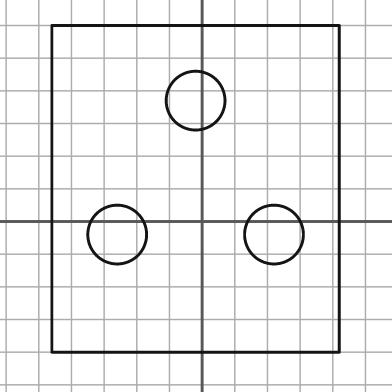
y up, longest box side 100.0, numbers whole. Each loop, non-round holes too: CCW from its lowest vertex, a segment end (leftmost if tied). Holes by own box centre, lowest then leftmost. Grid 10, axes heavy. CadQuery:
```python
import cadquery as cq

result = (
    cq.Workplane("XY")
    .moveTo(-46.0, -40.0)
    .lineTo(42.0, -40.0)
    .lineTo(42.0, 60.0)
    .lineTo(-46.0, 60.0)
    .close()
    .moveTo(-26.0, -4.0)
    .circle(9.0)
    .moveTo(22.0, -4.0)
    .circle(9.0)
    .moveTo(-2.0, 37.0)
    .circle(9.0)
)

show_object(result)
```